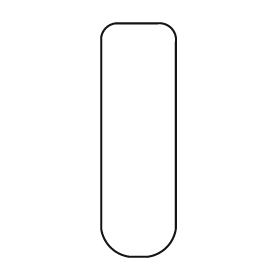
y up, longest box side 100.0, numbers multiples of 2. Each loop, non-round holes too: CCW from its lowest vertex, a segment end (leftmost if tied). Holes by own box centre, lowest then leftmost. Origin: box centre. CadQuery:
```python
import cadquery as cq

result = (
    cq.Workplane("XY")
    .moveTo(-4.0, -50.0)
    .lineTo(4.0, -50.0)
    .threePointArc((12.0, -46.0), (16.0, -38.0))
    .lineTo(16.0, 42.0)
    .threePointArc((14.0, 48.0), (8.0, 50.0))
    .lineTo(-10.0, 50.0)
    .threePointArc((-14.0, 48.0), (-16.0, 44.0))
    .lineTo(-16.0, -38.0)
    .threePointArc((-12.0, -46.0), (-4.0, -50.0))
    .close()
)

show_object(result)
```